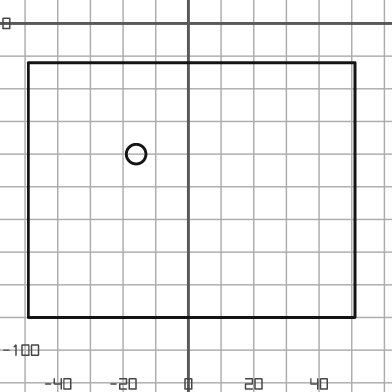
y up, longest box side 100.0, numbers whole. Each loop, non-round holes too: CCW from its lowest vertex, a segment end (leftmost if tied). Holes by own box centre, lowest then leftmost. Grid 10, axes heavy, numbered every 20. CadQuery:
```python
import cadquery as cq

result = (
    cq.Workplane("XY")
    .moveTo(-49.0, -90.0)
    .lineTo(51.0, -90.0)
    .lineTo(51.0, -12.0)
    .lineTo(-49.0, -12.0)
    .close()
    .moveTo(-16.0, -40.0)
    .circle(3.0)
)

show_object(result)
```